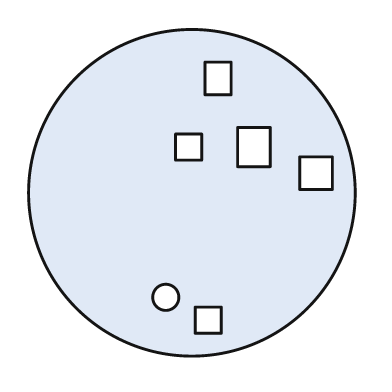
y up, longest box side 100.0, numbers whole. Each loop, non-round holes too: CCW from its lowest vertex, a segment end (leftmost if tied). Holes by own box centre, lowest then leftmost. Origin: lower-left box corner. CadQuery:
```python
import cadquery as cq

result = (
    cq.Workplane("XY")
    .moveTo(50.0, 50.0)
    .circle(50.0)
    .moveTo(51.0, 7.0)
    .lineTo(59.0, 7.0)
    .lineTo(59.0, 15.0)
    .lineTo(51.0, 15.0)
    .close()
    .moveTo(42.0, 18.0)
    .circle(4.0)
    .moveTo(83.0, 51.0)
    .lineTo(93.0, 51.0)
    .lineTo(93.0, 61.0)
    .lineTo(83.0, 61.0)
    .close()
    .moveTo(45.0, 60.0)
    .lineTo(53.0, 60.0)
    .lineTo(53.0, 68.0)
    .lineTo(45.0, 68.0)
    .close()
    .moveTo(64.0, 58.0)
    .lineTo(74.0, 58.0)
    .lineTo(74.0, 70.0)
    .lineTo(64.0, 70.0)
    .close()
    .moveTo(54.0, 80.0)
    .lineTo(62.0, 80.0)
    .lineTo(62.0, 90.0)
    .lineTo(54.0, 90.0)
    .close()
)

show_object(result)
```